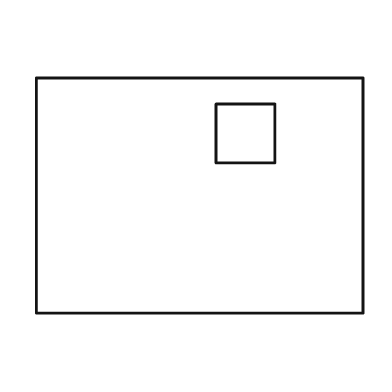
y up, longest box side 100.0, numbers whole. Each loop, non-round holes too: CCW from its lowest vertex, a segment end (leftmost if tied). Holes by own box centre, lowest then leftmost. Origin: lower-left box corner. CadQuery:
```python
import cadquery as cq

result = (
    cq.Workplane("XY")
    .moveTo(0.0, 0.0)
    .lineTo(100.0, 0.0)
    .lineTo(100.0, 72.0)
    .lineTo(0.0, 72.0)
    .close()
    .moveTo(55.0, 46.0)
    .lineTo(73.0, 46.0)
    .lineTo(73.0, 64.0)
    .lineTo(55.0, 64.0)
    .close()
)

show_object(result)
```